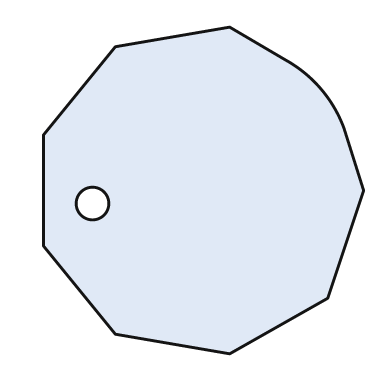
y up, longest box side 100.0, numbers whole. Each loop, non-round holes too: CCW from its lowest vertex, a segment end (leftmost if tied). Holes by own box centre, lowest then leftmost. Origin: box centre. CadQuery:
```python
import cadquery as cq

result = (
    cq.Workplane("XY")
    .moveTo(8.0, -50.0)
    .lineTo(38.0, -33.0)
    .lineTo(49.0, 0.0)
    .lineTo(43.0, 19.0)
    .threePointArc((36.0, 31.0), (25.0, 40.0))
    .lineTo(8.0, 50.0)
    .lineTo(-27.0, 44.0)
    .lineTo(-49.0, 17.0)
    .lineTo(-49.0, -17.0)
    .lineTo(-27.0, -44.0)
    .close()
    .moveTo(-34.0, -4.0)
    .circle(5.0)
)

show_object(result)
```